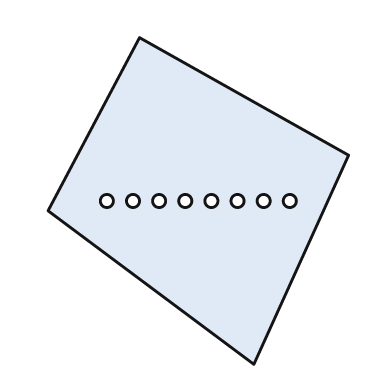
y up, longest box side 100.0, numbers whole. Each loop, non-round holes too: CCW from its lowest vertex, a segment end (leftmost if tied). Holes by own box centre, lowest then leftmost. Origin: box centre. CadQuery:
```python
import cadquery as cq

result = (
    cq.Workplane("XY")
    .moveTo(17.0, -50.0)
    .lineTo(46.0, 14.0)
    .lineTo(-18.0, 50.0)
    .lineTo(-46.0, -3.0)
    .close()
    .moveTo(-28.0, 0.0)
    .circle(2.0)
    .moveTo(-20.0, 0.0)
    .circle(2.0)
    .moveTo(-12.0, 0.0)
    .circle(2.0)
    .moveTo(-4.0, 0.0)
    .circle(2.0)
    .moveTo(4.0, 0.0)
    .circle(2.0)
    .moveTo(12.0, 0.0)
    .circle(2.0)
    .moveTo(20.0, 0.0)
    .circle(2.0)
    .moveTo(28.0, 0.0)
    .circle(2.0)
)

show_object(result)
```